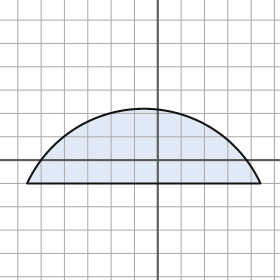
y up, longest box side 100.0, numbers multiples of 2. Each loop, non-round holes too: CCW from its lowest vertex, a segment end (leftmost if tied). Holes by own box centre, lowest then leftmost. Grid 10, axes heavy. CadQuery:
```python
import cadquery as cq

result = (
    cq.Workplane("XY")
    .moveTo(-56.0, -10.0)
    .lineTo(44.0, -10.0)
    .threePointArc((-6.0, 22.0), (-56.0, -10.0))
    .close()
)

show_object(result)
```